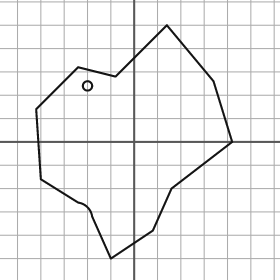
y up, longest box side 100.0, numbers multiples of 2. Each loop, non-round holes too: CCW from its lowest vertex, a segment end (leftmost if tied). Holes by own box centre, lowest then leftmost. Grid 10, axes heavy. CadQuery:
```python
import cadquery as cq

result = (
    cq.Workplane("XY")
    .moveTo(-10.0, -50.0)
    .lineTo(8.0, -38.0)
    .lineTo(16.0, -20.0)
    .lineTo(42.0, 0.0)
    .lineTo(34.0, 26.0)
    .lineTo(14.0, 50.0)
    .lineTo(-8.0, 28.0)
    .lineTo(-24.0, 32.0)
    .lineTo(-42.0, 14.0)
    .lineTo(-40.0, -16.0)
    .lineTo(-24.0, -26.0)
    .threePointArc((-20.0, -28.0), (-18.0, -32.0))
    .close()
    .moveTo(-20.0, 24.0)
    .circle(2.0)
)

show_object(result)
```